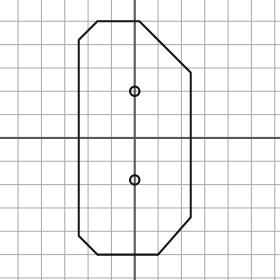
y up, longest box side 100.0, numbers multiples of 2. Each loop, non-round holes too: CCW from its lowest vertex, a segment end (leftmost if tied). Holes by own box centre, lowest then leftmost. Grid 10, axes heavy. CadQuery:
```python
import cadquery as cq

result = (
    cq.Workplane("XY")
    .moveTo(-16.0, -50.0)
    .lineTo(10.0, -50.0)
    .lineTo(24.0, -34.0)
    .lineTo(24.0, 28.0)
    .lineTo(2.0, 50.0)
    .lineTo(-16.0, 50.0)
    .lineTo(-24.0, 42.0)
    .lineTo(-24.0, -42.0)
    .close()
    .moveTo(0.0, -18.0)
    .circle(2.0)
    .moveTo(0.0, 20.0)
    .circle(2.0)
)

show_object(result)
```